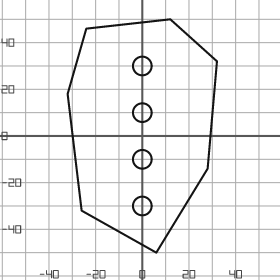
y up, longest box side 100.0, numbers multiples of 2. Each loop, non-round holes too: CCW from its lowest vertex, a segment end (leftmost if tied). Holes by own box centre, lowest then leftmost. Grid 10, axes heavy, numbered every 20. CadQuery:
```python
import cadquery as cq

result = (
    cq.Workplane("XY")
    .moveTo(6.0, -50.0)
    .lineTo(28.0, -14.0)
    .lineTo(32.0, 32.0)
    .lineTo(12.0, 50.0)
    .lineTo(-24.0, 46.0)
    .lineTo(-32.0, 18.0)
    .lineTo(-26.0, -32.0)
    .close()
    .moveTo(0.0, -30.0)
    .circle(4.0)
    .moveTo(0.0, -10.0)
    .circle(4.0)
    .moveTo(0.0, 10.0)
    .circle(4.0)
    .moveTo(0.0, 30.0)
    .circle(4.0)
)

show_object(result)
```